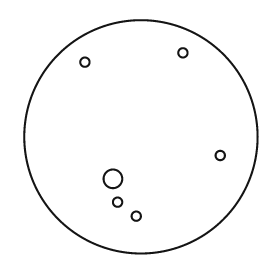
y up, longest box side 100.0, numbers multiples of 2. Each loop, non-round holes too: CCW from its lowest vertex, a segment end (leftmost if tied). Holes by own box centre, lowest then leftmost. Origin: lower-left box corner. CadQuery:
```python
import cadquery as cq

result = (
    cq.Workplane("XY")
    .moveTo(50.0, 50.0)
    .circle(50.0)
    .moveTo(48.0, 16.0)
    .circle(2.0)
    .moveTo(40.0, 22.0)
    .circle(2.0)
    .moveTo(38.0, 32.0)
    .circle(4.0)
    .moveTo(84.0, 42.0)
    .circle(2.0)
    .moveTo(26.0, 82.0)
    .circle(2.0)
    .moveTo(68.0, 86.0)
    .circle(2.0)
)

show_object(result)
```